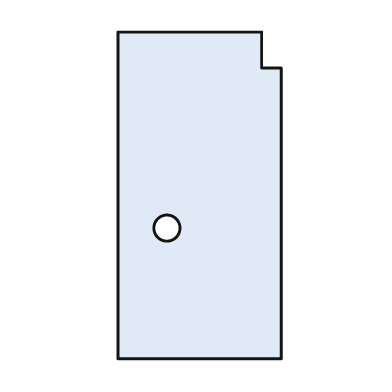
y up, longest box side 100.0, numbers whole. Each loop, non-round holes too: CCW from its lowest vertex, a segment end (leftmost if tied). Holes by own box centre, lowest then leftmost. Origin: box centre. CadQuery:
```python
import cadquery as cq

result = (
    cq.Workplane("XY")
    .moveTo(-25.0, -50.0)
    .lineTo(25.0, -50.0)
    .lineTo(25.0, 39.0)
    .lineTo(19.0, 39.0)
    .lineTo(19.0, 50.0)
    .lineTo(-25.0, 50.0)
    .close()
    .moveTo(-10.0, -10.0)
    .circle(4.0)
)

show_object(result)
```